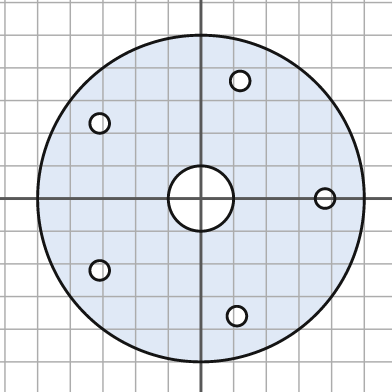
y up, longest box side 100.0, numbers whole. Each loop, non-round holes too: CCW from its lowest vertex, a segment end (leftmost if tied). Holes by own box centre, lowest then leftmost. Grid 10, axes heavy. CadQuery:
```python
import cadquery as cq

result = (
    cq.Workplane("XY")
    .moveTo(0.0, 0.0)
    .circle(50.0)
    .moveTo(11.0, -36.0)
    .circle(3.0)
    .moveTo(-31.0, -22.0)
    .circle(3.0)
    .moveTo(0.0, 0.0)
    .circle(10.0)
    .moveTo(38.0, 0.0)
    .circle(3.0)
    .moveTo(-31.0, 23.0)
    .circle(3.0)
    .moveTo(12.0, 36.0)
    .circle(3.0)
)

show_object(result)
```